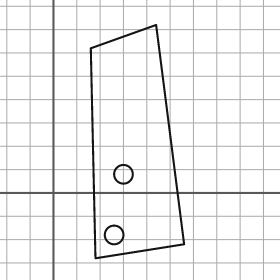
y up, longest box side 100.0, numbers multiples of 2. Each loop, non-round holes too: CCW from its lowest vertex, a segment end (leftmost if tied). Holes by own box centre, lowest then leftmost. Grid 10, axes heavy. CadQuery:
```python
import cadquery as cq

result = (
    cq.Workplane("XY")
    .moveTo(18.0, -28.0)
    .lineTo(56.0, -22.0)
    .lineTo(44.0, 72.0)
    .lineTo(16.0, 62.0)
    .close()
    .moveTo(26.0, -18.0)
    .circle(4.0)
    .moveTo(30.0, 8.0)
    .circle(4.0)
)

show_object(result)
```